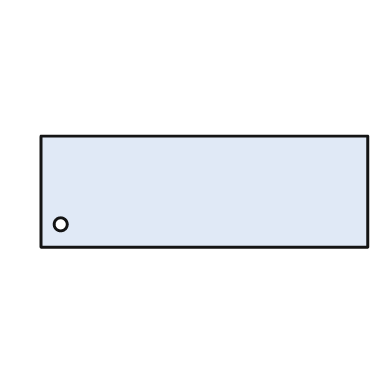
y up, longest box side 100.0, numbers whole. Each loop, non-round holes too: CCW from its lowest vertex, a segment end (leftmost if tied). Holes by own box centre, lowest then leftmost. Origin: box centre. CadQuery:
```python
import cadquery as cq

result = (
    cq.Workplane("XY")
    .moveTo(-50.0, -17.0)
    .lineTo(50.0, -17.0)
    .lineTo(50.0, 17.0)
    .lineTo(-50.0, 17.0)
    .close()
    .moveTo(-44.0, -10.0)
    .circle(2.0)
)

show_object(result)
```